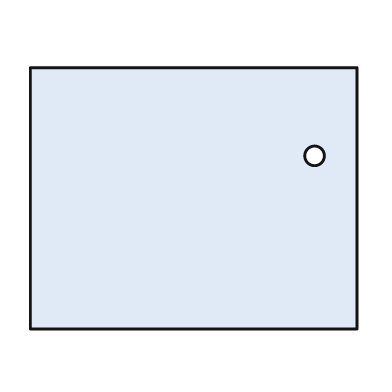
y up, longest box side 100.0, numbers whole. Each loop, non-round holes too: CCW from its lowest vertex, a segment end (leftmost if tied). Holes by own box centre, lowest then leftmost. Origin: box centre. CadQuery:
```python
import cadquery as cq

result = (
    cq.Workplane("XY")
    .moveTo(-50.0, -40.0)
    .lineTo(50.0, -40.0)
    .lineTo(50.0, 40.0)
    .lineTo(-50.0, 40.0)
    .close()
    .moveTo(37.0, 13.0)
    .circle(3.0)
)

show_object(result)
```